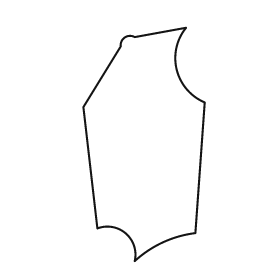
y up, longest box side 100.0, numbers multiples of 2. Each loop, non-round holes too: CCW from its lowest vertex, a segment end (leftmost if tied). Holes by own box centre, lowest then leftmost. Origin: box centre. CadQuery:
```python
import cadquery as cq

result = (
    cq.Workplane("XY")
    .moveTo(-4.0, -50.0)
    .threePointArc((8.0, -42.0), (22.0, -38.0))
    .lineTo(26.0, 18.0)
    .threePointArc((14.0, 32.0), (18.0, 50.0))
    .lineTo(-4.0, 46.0)
    .threePointArc((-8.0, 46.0), (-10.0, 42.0))
    .lineTo(-26.0, 16.0)
    .lineTo(-20.0, -36.0)
    .threePointArc((-8.0, -38.0), (-4.0, -50.0))
    .close()
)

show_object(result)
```